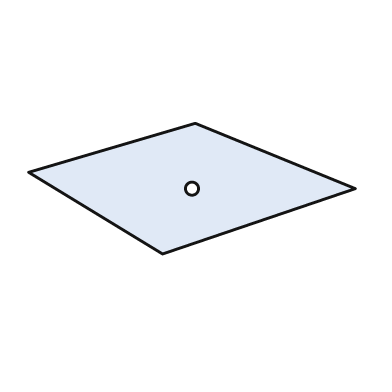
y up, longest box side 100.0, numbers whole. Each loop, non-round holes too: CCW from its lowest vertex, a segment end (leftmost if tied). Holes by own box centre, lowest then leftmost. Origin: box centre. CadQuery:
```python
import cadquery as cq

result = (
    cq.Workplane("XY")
    .moveTo(-9.0, -20.0)
    .lineTo(50.0, 0.0)
    .lineTo(1.0, 20.0)
    .lineTo(-50.0, 5.0)
    .close()
    .moveTo(0.0, 0.0)
    .circle(2.0)
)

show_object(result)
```